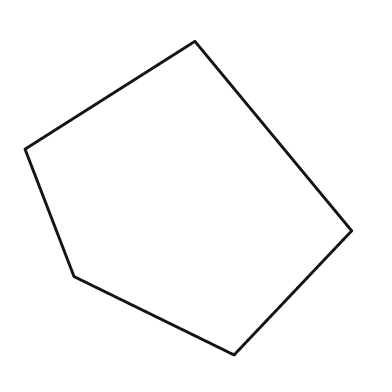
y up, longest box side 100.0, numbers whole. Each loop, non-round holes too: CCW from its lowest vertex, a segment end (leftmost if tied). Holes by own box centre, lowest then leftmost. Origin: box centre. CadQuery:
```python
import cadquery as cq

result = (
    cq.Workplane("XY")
    .moveTo(14.0, -48.0)
    .lineTo(50.0, -10.0)
    .lineTo(2.0, 48.0)
    .lineTo(-50.0, 15.0)
    .lineTo(-35.0, -24.0)
    .close()
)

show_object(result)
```